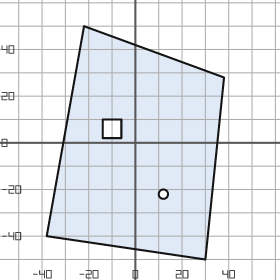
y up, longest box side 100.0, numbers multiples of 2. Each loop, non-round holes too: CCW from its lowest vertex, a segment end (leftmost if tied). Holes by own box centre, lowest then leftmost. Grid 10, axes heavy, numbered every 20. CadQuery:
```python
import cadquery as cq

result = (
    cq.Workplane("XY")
    .moveTo(30.0, -50.0)
    .lineTo(38.0, 28.0)
    .lineTo(-22.0, 50.0)
    .lineTo(-38.0, -40.0)
    .close()
    .moveTo(12.0, -22.0)
    .circle(2.0)
    .moveTo(-14.0, 2.0)
    .lineTo(-6.0, 2.0)
    .lineTo(-6.0, 10.0)
    .lineTo(-14.0, 10.0)
    .close()
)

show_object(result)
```